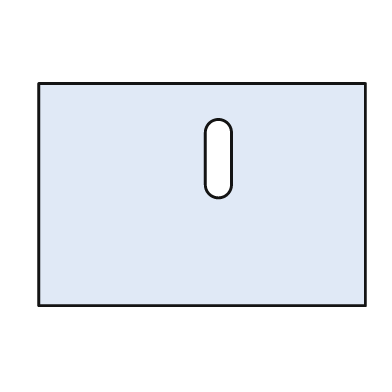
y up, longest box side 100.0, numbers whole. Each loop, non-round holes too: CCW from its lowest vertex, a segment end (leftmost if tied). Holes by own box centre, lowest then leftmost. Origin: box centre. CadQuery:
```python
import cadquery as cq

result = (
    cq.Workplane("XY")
    .moveTo(-50.0, -34.0)
    .lineTo(50.0, -34.0)
    .lineTo(50.0, 34.0)
    .lineTo(-50.0, 34.0)
    .close()
    .moveTo(1.0, 3.0)
    .threePointArc((5.0, -1.0), (9.0, 3.0))
    .lineTo(9.0, 19.0)
    .threePointArc((5.0, 23.0), (1.0, 19.0))
    .close()
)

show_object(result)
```